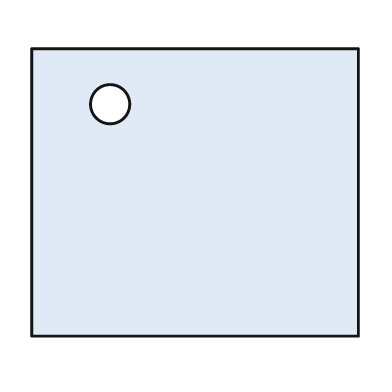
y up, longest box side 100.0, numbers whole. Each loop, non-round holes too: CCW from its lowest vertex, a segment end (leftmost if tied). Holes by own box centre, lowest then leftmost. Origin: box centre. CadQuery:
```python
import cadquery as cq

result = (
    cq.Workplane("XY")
    .moveTo(-50.0, -44.0)
    .lineTo(50.0, -44.0)
    .lineTo(50.0, 44.0)
    .lineTo(-50.0, 44.0)
    .close()
    .moveTo(-26.0, 27.0)
    .circle(6.0)
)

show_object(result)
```